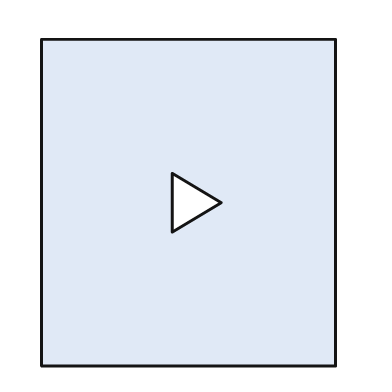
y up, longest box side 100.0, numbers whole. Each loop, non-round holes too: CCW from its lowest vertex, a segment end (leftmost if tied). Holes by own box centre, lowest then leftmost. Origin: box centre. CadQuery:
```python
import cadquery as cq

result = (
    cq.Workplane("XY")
    .moveTo(-45.0, -50.0)
    .lineTo(45.0, -50.0)
    .lineTo(45.0, 50.0)
    .lineTo(-45.0, 50.0)
    .close()
    .moveTo(-5.0, -9.0)
    .lineTo(10.0, 0.0)
    .lineTo(-5.0, 9.0)
    .close()
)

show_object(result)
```